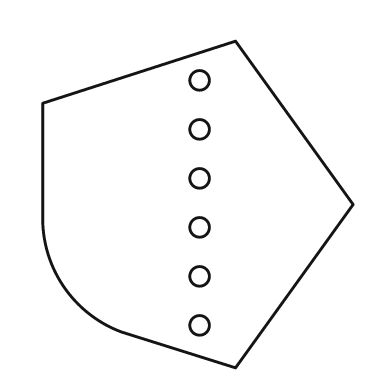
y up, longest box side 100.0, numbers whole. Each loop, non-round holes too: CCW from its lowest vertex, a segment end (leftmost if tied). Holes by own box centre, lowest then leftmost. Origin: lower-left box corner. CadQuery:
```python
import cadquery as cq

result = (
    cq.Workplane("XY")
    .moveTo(59.0, 0.0)
    .lineTo(95.0, 50.0)
    .lineTo(59.0, 100.0)
    .lineTo(0.0, 81.0)
    .lineTo(0.0, 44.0)
    .threePointArc((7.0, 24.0), (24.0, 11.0))
    .close()
    .moveTo(48.0, 13.0)
    .circle(3.0)
    .moveTo(48.0, 28.0)
    .circle(3.0)
    .moveTo(48.0, 43.0)
    .circle(3.0)
    .moveTo(48.0, 58.0)
    .circle(3.0)
    .moveTo(48.0, 73.0)
    .circle(3.0)
    .moveTo(48.0, 88.0)
    .circle(3.0)
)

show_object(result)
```